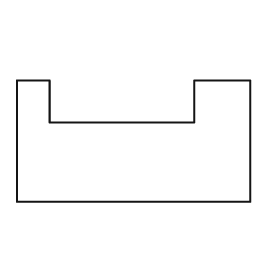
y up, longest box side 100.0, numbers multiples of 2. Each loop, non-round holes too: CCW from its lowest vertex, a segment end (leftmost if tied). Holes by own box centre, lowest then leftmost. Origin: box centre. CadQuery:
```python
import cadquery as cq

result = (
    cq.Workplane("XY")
    .moveTo(-50.0, -26.0)
    .lineTo(50.0, -26.0)
    .lineTo(50.0, 26.0)
    .lineTo(26.0, 26.0)
    .lineTo(26.0, 8.0)
    .lineTo(-36.0, 8.0)
    .lineTo(-36.0, 26.0)
    .lineTo(-50.0, 26.0)
    .close()
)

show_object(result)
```